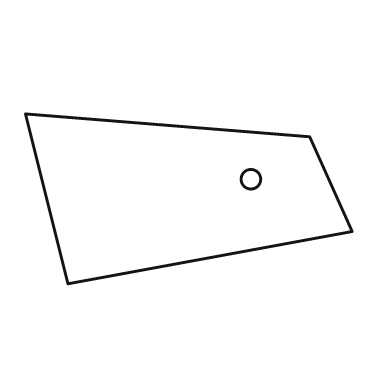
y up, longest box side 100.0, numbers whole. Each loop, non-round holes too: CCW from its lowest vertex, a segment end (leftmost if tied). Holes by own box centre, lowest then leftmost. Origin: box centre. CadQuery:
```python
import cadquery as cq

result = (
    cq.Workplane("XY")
    .moveTo(-37.0, -26.0)
    .lineTo(50.0, -10.0)
    .lineTo(37.0, 19.0)
    .lineTo(-50.0, 26.0)
    .close()
    .moveTo(19.0, 6.0)
    .circle(3.0)
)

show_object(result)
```